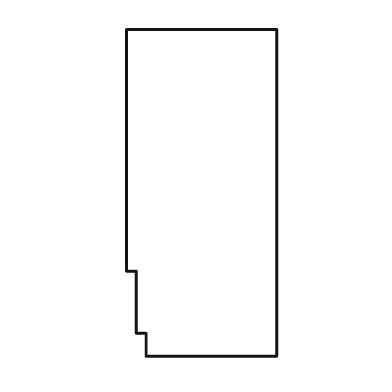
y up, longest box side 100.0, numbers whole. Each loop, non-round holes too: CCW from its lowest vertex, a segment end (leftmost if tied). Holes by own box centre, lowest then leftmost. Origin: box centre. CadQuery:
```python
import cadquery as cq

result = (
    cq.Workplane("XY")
    .moveTo(-17.0, -50.0)
    .lineTo(23.0, -50.0)
    .lineTo(23.0, 50.0)
    .lineTo(-23.0, 50.0)
    .lineTo(-23.0, -24.0)
    .lineTo(-20.0, -24.0)
    .lineTo(-20.0, -43.0)
    .lineTo(-17.0, -43.0)
    .close()
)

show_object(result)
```